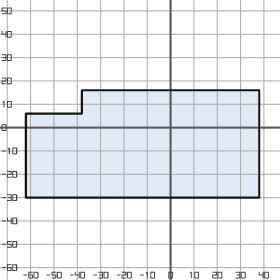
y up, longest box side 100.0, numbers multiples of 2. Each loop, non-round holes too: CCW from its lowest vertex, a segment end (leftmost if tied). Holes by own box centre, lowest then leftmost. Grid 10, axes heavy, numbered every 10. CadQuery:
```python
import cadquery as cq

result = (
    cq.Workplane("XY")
    .moveTo(-62.0, -30.0)
    .lineTo(38.0, -30.0)
    .lineTo(38.0, 16.0)
    .lineTo(-38.0, 16.0)
    .lineTo(-38.0, 6.0)
    .lineTo(-62.0, 6.0)
    .close()
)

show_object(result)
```